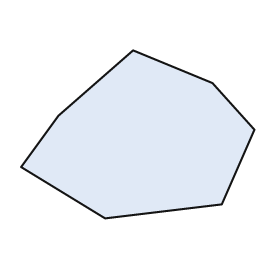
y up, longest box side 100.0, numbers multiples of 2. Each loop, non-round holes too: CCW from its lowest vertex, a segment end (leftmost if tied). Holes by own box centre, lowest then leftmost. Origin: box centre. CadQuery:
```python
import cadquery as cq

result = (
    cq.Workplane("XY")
    .moveTo(-14.0, -36.0)
    .lineTo(36.0, -30.0)
    .lineTo(50.0, 2.0)
    .lineTo(32.0, 22.0)
    .lineTo(-2.0, 36.0)
    .lineTo(-34.0, 8.0)
    .lineTo(-50.0, -14.0)
    .close()
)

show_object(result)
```